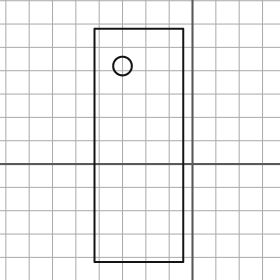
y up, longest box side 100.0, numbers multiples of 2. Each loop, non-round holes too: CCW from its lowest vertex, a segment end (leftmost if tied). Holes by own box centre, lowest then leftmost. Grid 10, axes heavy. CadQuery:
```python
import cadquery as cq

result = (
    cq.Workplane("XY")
    .moveTo(-42.0, -42.0)
    .lineTo(-4.0, -42.0)
    .lineTo(-4.0, 58.0)
    .lineTo(-42.0, 58.0)
    .close()
    .moveTo(-30.0, 42.0)
    .circle(4.0)
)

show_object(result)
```